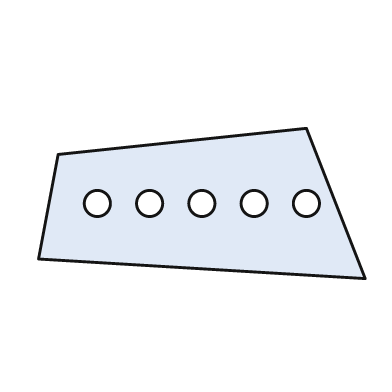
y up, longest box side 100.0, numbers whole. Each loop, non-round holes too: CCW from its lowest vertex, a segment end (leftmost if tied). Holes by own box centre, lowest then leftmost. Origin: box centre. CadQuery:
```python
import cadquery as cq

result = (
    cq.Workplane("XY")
    .moveTo(50.0, -23.0)
    .lineTo(32.0, 23.0)
    .lineTo(-44.0, 15.0)
    .lineTo(-50.0, -17.0)
    .close()
    .moveTo(-32.0, 0.0)
    .circle(4.0)
    .moveTo(-16.0, 0.0)
    .circle(4.0)
    .moveTo(0.0, 0.0)
    .circle(4.0)
    .moveTo(16.0, 0.0)
    .circle(4.0)
    .moveTo(32.0, 0.0)
    .circle(4.0)
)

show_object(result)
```